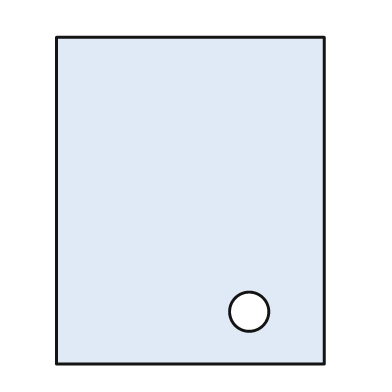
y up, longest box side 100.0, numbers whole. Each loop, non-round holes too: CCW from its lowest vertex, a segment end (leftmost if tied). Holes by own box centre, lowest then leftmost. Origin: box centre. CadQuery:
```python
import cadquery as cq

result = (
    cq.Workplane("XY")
    .moveTo(-41.0, -50.0)
    .lineTo(41.0, -50.0)
    .lineTo(41.0, 50.0)
    .lineTo(-41.0, 50.0)
    .close()
    .moveTo(18.0, -34.0)
    .circle(6.0)
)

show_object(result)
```